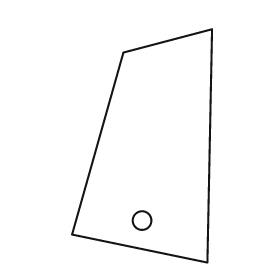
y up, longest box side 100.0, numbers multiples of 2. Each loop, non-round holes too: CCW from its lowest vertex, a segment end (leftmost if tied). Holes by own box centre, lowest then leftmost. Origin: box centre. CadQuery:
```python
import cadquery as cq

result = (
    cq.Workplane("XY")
    .moveTo(28.0, -50.0)
    .lineTo(30.0, 50.0)
    .lineTo(-8.0, 40.0)
    .lineTo(-30.0, -38.0)
    .close()
    .moveTo(0.0, -32.0)
    .circle(4.0)
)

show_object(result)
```